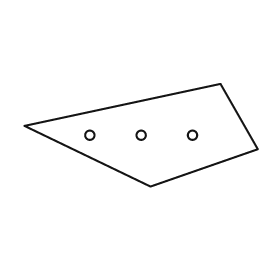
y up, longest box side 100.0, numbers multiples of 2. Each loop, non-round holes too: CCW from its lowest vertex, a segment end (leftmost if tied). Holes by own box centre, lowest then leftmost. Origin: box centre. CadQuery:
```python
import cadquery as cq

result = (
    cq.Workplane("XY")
    .moveTo(4.0, -22.0)
    .lineTo(50.0, -6.0)
    .lineTo(34.0, 22.0)
    .lineTo(-50.0, 4.0)
    .close()
    .moveTo(-22.0, 0.0)
    .circle(2.0)
    .moveTo(0.0, 0.0)
    .circle(2.0)
    .moveTo(22.0, 0.0)
    .circle(2.0)
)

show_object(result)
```